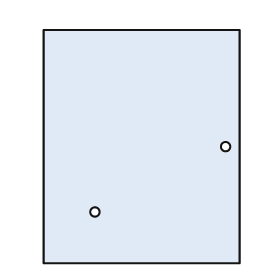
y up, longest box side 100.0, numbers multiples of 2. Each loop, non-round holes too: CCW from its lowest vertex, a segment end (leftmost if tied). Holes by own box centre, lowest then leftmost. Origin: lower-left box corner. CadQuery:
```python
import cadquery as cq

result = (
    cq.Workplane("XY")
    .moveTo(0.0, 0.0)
    .lineTo(84.0, 0.0)
    .lineTo(84.0, 100.0)
    .lineTo(0.0, 100.0)
    .close()
    .moveTo(22.0, 22.0)
    .circle(2.0)
    .moveTo(78.0, 50.0)
    .circle(2.0)
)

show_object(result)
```